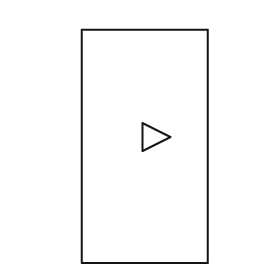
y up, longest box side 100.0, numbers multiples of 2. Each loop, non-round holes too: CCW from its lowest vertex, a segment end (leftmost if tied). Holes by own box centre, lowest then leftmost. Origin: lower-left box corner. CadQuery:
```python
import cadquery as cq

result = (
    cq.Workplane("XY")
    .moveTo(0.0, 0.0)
    .lineTo(54.0, 0.0)
    .lineTo(54.0, 100.0)
    .lineTo(0.0, 100.0)
    .close()
    .moveTo(26.0, 48.0)
    .lineTo(38.0, 54.0)
    .lineTo(26.0, 60.0)
    .close()
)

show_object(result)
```